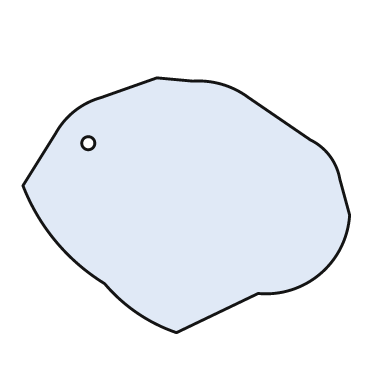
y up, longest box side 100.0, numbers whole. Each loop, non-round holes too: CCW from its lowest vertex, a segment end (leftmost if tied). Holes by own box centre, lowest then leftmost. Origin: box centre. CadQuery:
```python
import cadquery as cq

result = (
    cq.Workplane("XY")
    .moveTo(-3.0, -39.0)
    .lineTo(22.0, -27.0)
    .threePointArc((41.0, -21.0), (50.0, -3.0))
    .lineTo(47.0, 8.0)
    .threePointArc((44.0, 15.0), (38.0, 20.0))
    .lineTo(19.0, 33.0)
    .threePointArc((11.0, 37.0), (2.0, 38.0))
    .lineTo(-9.0, 39.0)
    .lineTo(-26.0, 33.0)
    .threePointArc((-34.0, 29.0), (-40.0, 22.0))
    .lineTo(-50.0, 6.0)
    .threePointArc((-40.0, -11.0), (-25.0, -24.0))
    .threePointArc((-15.0, -33.0), (-3.0, -39.0))
    .close()
    .moveTo(-30.0, 19.0)
    .circle(2.0)
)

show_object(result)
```